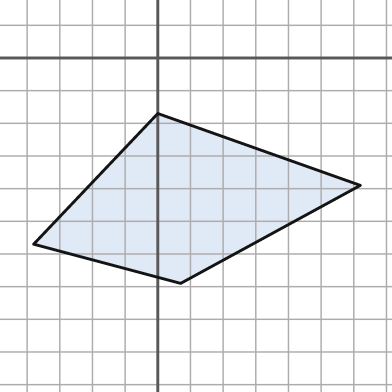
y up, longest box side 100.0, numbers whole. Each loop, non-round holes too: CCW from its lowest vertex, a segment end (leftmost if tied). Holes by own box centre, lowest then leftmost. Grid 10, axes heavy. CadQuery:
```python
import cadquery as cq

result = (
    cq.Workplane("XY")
    .moveTo(7.0, -69.0)
    .lineTo(62.0, -39.0)
    .lineTo(0.0, -17.0)
    .lineTo(-38.0, -57.0)
    .close()
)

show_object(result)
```